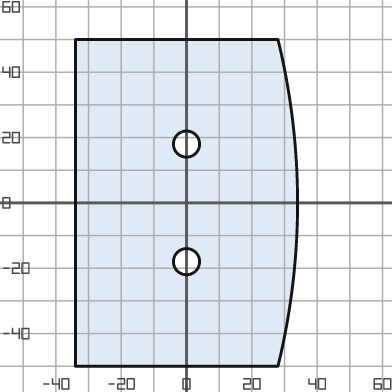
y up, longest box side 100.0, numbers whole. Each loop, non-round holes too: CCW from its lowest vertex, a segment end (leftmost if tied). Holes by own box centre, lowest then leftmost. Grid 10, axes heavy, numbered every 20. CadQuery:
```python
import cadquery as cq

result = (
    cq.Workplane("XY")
    .moveTo(-34.0, -50.0)
    .lineTo(28.0, -50.0)
    .threePointArc((34.0, 0.0), (28.0, 50.0))
    .lineTo(-34.0, 50.0)
    .close()
    .moveTo(0.0, -18.0)
    .circle(4.0)
    .moveTo(0.0, 18.0)
    .circle(4.0)
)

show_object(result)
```